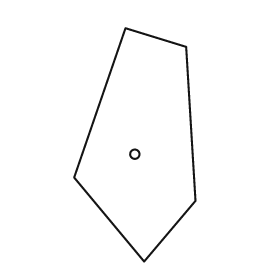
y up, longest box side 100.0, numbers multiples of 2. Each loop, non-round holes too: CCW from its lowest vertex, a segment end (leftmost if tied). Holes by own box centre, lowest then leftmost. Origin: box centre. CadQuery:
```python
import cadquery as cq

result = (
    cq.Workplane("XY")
    .moveTo(4.0, -50.0)
    .lineTo(26.0, -24.0)
    .lineTo(22.0, 42.0)
    .lineTo(-4.0, 50.0)
    .lineTo(-26.0, -14.0)
    .close()
    .moveTo(0.0, -4.0)
    .circle(2.0)
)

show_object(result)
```